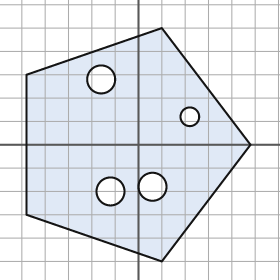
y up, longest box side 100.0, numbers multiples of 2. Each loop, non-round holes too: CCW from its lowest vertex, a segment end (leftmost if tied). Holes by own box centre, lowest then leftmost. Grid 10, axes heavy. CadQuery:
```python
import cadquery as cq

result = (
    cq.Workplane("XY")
    .moveTo(10.0, -50.0)
    .lineTo(48.0, 0.0)
    .lineTo(10.0, 50.0)
    .lineTo(-48.0, 30.0)
    .lineTo(-48.0, -30.0)
    .close()
    .moveTo(-12.0, -20.0)
    .circle(6.0)
    .moveTo(6.0, -18.0)
    .circle(6.0)
    .moveTo(22.0, 12.0)
    .circle(4.0)
    .moveTo(-16.0, 28.0)
    .circle(6.0)
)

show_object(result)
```